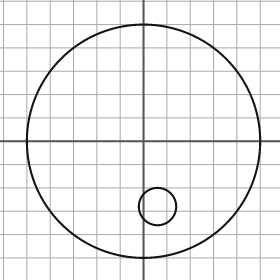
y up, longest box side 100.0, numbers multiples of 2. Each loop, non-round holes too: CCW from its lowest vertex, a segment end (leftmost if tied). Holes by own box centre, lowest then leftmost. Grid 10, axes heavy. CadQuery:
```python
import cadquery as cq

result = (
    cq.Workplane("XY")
    .moveTo(0.0, 0.0)
    .circle(50.0)
    .moveTo(6.0, -28.0)
    .circle(8.0)
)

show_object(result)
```